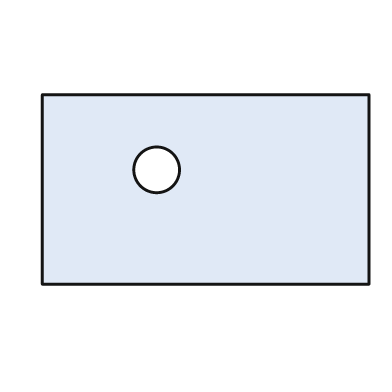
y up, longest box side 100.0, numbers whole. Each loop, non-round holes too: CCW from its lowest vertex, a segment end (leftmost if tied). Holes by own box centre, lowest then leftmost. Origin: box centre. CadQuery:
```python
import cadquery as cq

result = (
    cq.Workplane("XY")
    .moveTo(-50.0, -29.0)
    .lineTo(50.0, -29.0)
    .lineTo(50.0, 29.0)
    .lineTo(-50.0, 29.0)
    .close()
    .moveTo(-15.0, 6.0)
    .circle(7.0)
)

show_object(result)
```